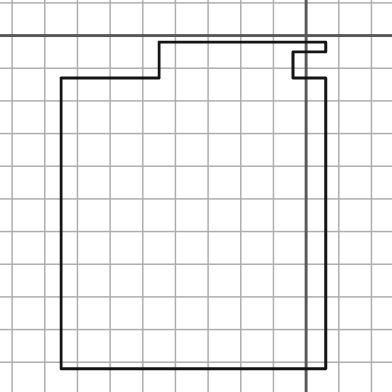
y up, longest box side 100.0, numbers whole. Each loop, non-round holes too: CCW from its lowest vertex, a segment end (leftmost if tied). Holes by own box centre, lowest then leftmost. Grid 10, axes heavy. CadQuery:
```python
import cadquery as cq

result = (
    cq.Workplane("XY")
    .moveTo(-75.0, -102.0)
    .lineTo(6.0, -102.0)
    .lineTo(6.0, -13.0)
    .lineTo(-4.0, -13.0)
    .lineTo(-4.0, -5.0)
    .lineTo(6.0, -5.0)
    .lineTo(6.0, -2.0)
    .lineTo(-45.0, -2.0)
    .lineTo(-45.0, -13.0)
    .lineTo(-75.0, -13.0)
    .close()
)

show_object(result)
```